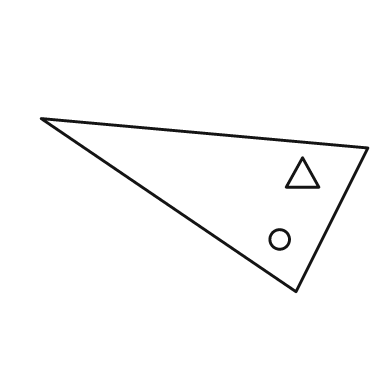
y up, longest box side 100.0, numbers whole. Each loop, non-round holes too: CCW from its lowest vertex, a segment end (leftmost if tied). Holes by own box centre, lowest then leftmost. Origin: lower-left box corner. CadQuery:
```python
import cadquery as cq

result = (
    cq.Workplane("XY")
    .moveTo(78.0, 0.0)
    .lineTo(100.0, 44.0)
    .lineTo(0.0, 53.0)
    .close()
    .moveTo(73.0, 16.0)
    .circle(3.0)
    .moveTo(75.0, 32.0)
    .lineTo(85.0, 32.0)
    .lineTo(80.0, 41.0)
    .close()
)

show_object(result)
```